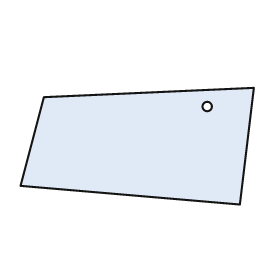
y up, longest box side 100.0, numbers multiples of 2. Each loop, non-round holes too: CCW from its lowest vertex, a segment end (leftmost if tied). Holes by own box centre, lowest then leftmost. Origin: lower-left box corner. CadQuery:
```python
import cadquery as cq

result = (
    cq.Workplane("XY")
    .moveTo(94.0, 0.0)
    .lineTo(100.0, 50.0)
    .lineTo(10.0, 46.0)
    .lineTo(0.0, 8.0)
    .close()
    .moveTo(80.0, 42.0)
    .circle(2.0)
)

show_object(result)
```